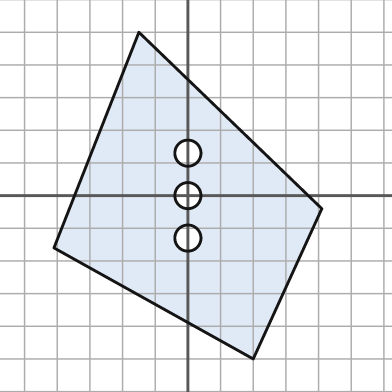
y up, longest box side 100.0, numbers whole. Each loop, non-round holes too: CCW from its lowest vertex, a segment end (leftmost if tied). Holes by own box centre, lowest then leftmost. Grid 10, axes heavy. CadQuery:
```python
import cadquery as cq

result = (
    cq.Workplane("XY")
    .moveTo(20.0, -50.0)
    .lineTo(41.0, -4.0)
    .lineTo(-15.0, 50.0)
    .lineTo(-41.0, -16.0)
    .close()
    .moveTo(0.0, -13.0)
    .circle(4.0)
    .moveTo(0.0, 0.0)
    .circle(4.0)
    .moveTo(0.0, 13.0)
    .circle(4.0)
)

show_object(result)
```